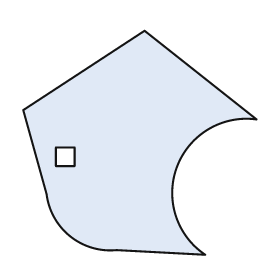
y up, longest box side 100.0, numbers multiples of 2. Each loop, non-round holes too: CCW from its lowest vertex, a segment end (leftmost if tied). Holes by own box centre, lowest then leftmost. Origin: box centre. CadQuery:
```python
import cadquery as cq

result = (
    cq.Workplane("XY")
    .moveTo(28.0, -48.0)
    .threePointArc((16.0, -10.0), (50.0, 10.0))
    .lineTo(2.0, 48.0)
    .lineTo(-50.0, 14.0)
    .lineTo(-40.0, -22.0)
    .threePointArc((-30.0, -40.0), (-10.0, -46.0))
    .close()
    .moveTo(-36.0, -10.0)
    .lineTo(-28.0, -10.0)
    .lineTo(-28.0, -2.0)
    .lineTo(-36.0, -2.0)
    .close()
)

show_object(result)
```